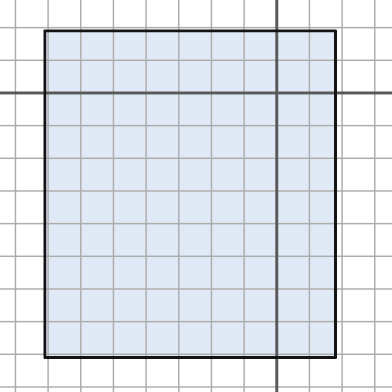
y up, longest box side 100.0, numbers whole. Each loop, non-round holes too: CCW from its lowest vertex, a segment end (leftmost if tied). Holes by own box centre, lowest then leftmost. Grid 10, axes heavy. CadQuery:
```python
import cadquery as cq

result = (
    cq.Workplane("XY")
    .moveTo(-71.0, -81.0)
    .lineTo(18.0, -81.0)
    .lineTo(18.0, 19.0)
    .lineTo(-71.0, 19.0)
    .close()
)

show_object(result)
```